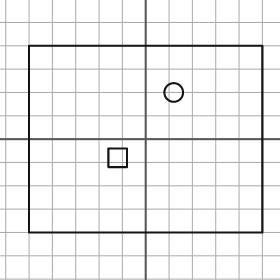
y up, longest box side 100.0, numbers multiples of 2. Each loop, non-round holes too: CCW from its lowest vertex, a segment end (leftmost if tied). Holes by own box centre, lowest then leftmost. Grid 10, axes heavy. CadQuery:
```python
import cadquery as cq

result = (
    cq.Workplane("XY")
    .moveTo(-50.0, -40.0)
    .lineTo(50.0, -40.0)
    .lineTo(50.0, 40.0)
    .lineTo(-50.0, 40.0)
    .close()
    .moveTo(-16.0, -12.0)
    .lineTo(-8.0, -12.0)
    .lineTo(-8.0, -4.0)
    .lineTo(-16.0, -4.0)
    .close()
    .moveTo(12.0, 20.0)
    .circle(4.0)
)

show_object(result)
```